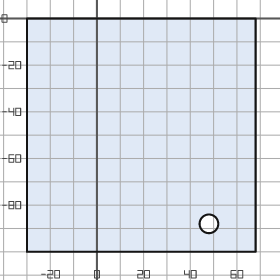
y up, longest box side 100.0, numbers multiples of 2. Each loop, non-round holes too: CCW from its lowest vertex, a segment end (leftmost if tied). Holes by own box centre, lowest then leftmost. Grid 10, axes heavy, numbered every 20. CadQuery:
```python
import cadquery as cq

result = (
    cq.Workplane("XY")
    .moveTo(-30.0, -100.0)
    .lineTo(68.0, -100.0)
    .lineTo(68.0, 0.0)
    .lineTo(-30.0, 0.0)
    .close()
    .moveTo(48.0, -88.0)
    .circle(4.0)
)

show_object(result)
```